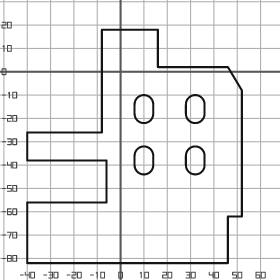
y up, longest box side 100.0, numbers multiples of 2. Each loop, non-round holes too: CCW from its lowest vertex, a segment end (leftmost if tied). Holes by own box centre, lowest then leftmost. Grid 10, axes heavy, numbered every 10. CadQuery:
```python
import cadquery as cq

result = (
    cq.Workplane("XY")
    .moveTo(-40.0, -82.0)
    .lineTo(46.0, -82.0)
    .lineTo(46.0, -62.0)
    .lineTo(52.0, -62.0)
    .lineTo(52.0, -8.0)
    .lineTo(46.0, 2.0)
    .lineTo(16.0, 2.0)
    .lineTo(16.0, 18.0)
    .lineTo(-8.0, 18.0)
    .lineTo(-8.0, -26.0)
    .lineTo(-40.0, -26.0)
    .lineTo(-40.0, -38.0)
    .lineTo(-6.0, -38.0)
    .lineTo(-6.0, -56.0)
    .lineTo(-40.0, -56.0)
    .close()
    .moveTo(6.0, -40.0)
    .threePointArc((10.0, -44.0), (14.0, -40.0))
    .lineTo(14.0, -36.0)
    .threePointArc((10.0, -32.0), (6.0, -36.0))
    .close()
    .moveTo(28.0, -40.0)
    .threePointArc((32.0, -44.0), (36.0, -40.0))
    .lineTo(36.0, -36.0)
    .threePointArc((32.0, -32.0), (28.0, -36.0))
    .close()
    .moveTo(6.0, -18.0)
    .threePointArc((10.0, -22.0), (14.0, -18.0))
    .lineTo(14.0, -14.0)
    .threePointArc((10.0, -10.0), (6.0, -14.0))
    .close()
    .moveTo(28.0, -18.0)
    .threePointArc((32.0, -22.0), (36.0, -18.0))
    .lineTo(36.0, -14.0)
    .threePointArc((32.0, -10.0), (28.0, -14.0))
    .close()
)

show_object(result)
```